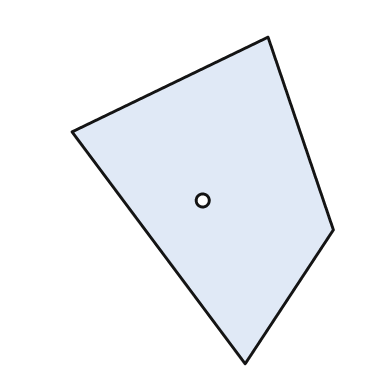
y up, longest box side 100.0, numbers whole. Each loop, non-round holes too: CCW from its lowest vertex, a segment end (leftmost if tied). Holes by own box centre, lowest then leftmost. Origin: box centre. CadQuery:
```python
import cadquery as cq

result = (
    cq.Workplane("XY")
    .moveTo(13.0, -50.0)
    .lineTo(40.0, -9.0)
    .lineTo(20.0, 50.0)
    .lineTo(-40.0, 21.0)
    .close()
    .moveTo(0.0, 0.0)
    .circle(2.0)
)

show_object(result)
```